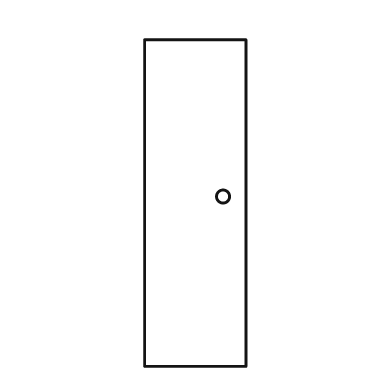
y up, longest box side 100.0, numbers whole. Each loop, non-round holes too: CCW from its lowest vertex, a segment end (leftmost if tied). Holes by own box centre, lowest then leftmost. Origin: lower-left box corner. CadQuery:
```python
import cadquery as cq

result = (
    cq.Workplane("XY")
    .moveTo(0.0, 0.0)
    .lineTo(31.0, 0.0)
    .lineTo(31.0, 100.0)
    .lineTo(0.0, 100.0)
    .close()
    .moveTo(24.0, 52.0)
    .circle(2.0)
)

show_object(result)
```